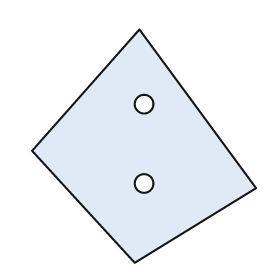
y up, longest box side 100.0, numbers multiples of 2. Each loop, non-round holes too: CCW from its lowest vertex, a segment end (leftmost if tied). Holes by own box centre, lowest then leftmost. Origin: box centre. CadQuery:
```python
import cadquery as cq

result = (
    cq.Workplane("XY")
    .moveTo(-4.0, -50.0)
    .lineTo(48.0, -18.0)
    .lineTo(-2.0, 50.0)
    .lineTo(-48.0, -2.0)
    .close()
    .moveTo(0.0, -16.0)
    .circle(4.0)
    .moveTo(0.0, 18.0)
    .circle(4.0)
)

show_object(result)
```